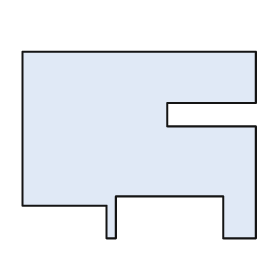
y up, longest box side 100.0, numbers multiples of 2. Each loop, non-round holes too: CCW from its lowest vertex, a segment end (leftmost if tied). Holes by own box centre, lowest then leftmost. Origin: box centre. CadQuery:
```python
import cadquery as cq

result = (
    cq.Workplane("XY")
    .moveTo(-14.0, -40.0)
    .lineTo(-10.0, -40.0)
    .lineTo(-10.0, -22.0)
    .lineTo(36.0, -22.0)
    .lineTo(36.0, -40.0)
    .lineTo(50.0, -40.0)
    .lineTo(50.0, 8.0)
    .lineTo(12.0, 8.0)
    .lineTo(12.0, 18.0)
    .lineTo(50.0, 18.0)
    .lineTo(50.0, 40.0)
    .lineTo(-50.0, 40.0)
    .lineTo(-50.0, -26.0)
    .lineTo(-14.0, -26.0)
    .close()
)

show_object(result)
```